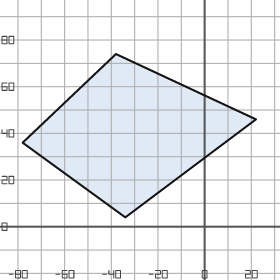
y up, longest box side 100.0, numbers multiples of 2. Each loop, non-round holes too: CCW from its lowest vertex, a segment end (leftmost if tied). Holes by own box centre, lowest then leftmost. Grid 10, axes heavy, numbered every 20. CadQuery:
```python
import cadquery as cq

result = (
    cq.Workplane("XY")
    .moveTo(-34.0, 4.0)
    .lineTo(22.0, 46.0)
    .lineTo(-38.0, 74.0)
    .lineTo(-78.0, 36.0)
    .close()
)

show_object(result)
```